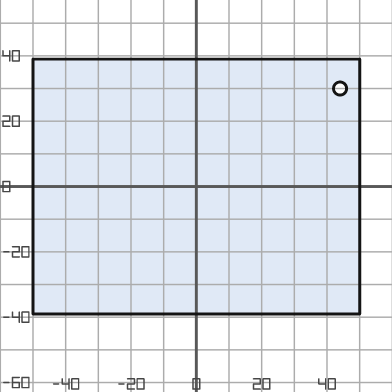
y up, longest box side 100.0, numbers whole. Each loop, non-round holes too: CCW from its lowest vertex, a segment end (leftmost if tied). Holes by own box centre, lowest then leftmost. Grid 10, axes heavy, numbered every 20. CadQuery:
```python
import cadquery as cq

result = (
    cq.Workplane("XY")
    .moveTo(-50.0, -39.0)
    .lineTo(50.0, -39.0)
    .lineTo(50.0, 39.0)
    .lineTo(-50.0, 39.0)
    .close()
    .moveTo(44.0, 30.0)
    .circle(2.0)
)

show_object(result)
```